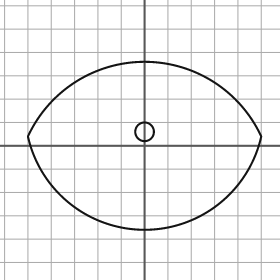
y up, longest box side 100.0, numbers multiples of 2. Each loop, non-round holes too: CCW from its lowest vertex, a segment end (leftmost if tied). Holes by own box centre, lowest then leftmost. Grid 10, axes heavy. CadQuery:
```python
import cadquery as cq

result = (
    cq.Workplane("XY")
    .moveTo(-50.0, 4.0)
    .threePointArc((0.0, -36.0), (50.0, 4.0))
    .threePointArc((0.0, 36.0), (-50.0, 4.0))
    .close()
    .moveTo(0.0, 6.0)
    .circle(4.0)
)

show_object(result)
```